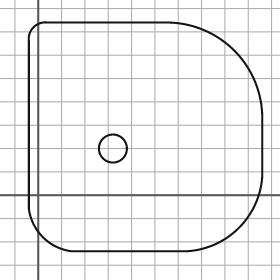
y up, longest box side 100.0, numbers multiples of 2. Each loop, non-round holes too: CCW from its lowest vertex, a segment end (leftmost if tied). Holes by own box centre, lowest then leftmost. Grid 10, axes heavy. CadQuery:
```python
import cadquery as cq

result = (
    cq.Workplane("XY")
    .moveTo(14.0, -24.0)
    .lineTo(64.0, -24.0)
    .threePointArc((86.0, -14.0), (96.0, 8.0))
    .lineTo(96.0, 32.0)
    .threePointArc((84.0, 62.0), (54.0, 74.0))
    .lineTo(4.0, 74.0)
    .threePointArc((-2.0, 72.0), (-4.0, 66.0))
    .lineTo(-4.0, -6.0)
    .threePointArc((2.0, -18.0), (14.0, -24.0))
    .close()
    .moveTo(32.0, 20.0)
    .circle(6.0)
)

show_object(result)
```